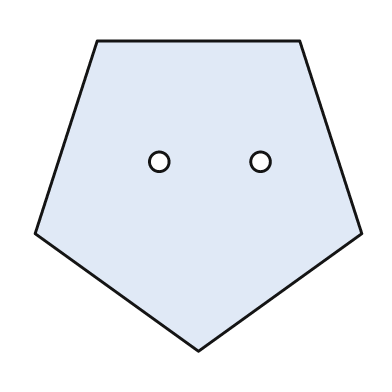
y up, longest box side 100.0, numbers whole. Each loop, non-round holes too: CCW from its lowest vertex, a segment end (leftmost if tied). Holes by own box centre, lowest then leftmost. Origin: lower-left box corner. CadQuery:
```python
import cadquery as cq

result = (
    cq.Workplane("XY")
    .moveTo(50.0, 0.0)
    .lineTo(100.0, 36.0)
    .lineTo(81.0, 95.0)
    .lineTo(19.0, 95.0)
    .lineTo(0.0, 36.0)
    .close()
    .moveTo(38.0, 58.0)
    .circle(3.0)
    .moveTo(69.0, 58.0)
    .circle(3.0)
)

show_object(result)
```